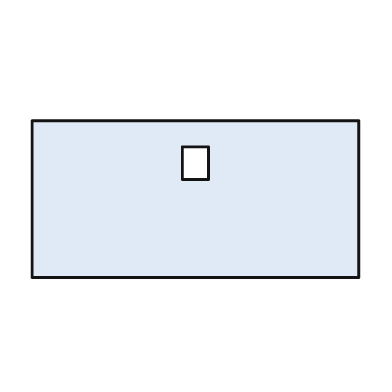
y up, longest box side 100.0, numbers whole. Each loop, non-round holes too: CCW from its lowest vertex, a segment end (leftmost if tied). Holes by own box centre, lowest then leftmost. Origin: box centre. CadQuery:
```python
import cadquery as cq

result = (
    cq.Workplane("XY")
    .moveTo(-50.0, -24.0)
    .lineTo(50.0, -24.0)
    .lineTo(50.0, 24.0)
    .lineTo(-50.0, 24.0)
    .close()
    .moveTo(-4.0, 6.0)
    .lineTo(4.0, 6.0)
    .lineTo(4.0, 16.0)
    .lineTo(-4.0, 16.0)
    .close()
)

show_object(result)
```